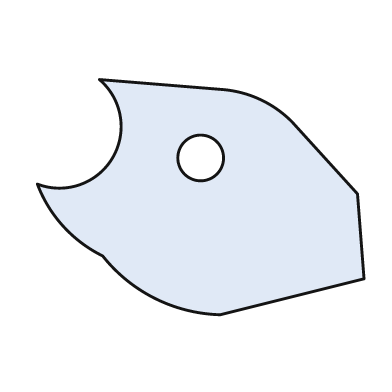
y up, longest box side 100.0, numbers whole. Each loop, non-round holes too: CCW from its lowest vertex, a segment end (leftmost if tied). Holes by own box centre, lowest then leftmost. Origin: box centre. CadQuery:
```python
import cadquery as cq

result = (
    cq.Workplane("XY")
    .moveTo(6.0, -36.0)
    .lineTo(50.0, -25.0)
    .lineTo(48.0, 1.0)
    .lineTo(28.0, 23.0)
    .threePointArc((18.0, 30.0), (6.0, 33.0))
    .lineTo(-31.0, 36.0)
    .threePointArc((-27.0, 12.0), (-50.0, 4.0))
    .threePointArc((-42.0, -9.0), (-30.0, -18.0))
    .threePointArc((-14.0, -31.0), (6.0, -36.0))
    .close()
    .moveTo(0.0, 12.0)
    .circle(7.0)
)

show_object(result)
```